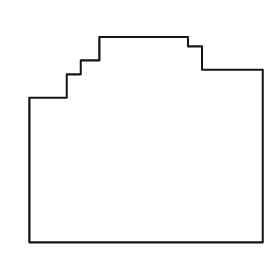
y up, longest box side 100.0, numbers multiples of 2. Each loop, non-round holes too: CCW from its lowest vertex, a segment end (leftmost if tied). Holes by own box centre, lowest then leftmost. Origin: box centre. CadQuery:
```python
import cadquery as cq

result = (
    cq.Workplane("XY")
    .moveTo(-50.0, -44.0)
    .lineTo(50.0, -44.0)
    .lineTo(50.0, 30.0)
    .lineTo(24.0, 30.0)
    .lineTo(24.0, 40.0)
    .lineTo(18.0, 40.0)
    .lineTo(18.0, 44.0)
    .lineTo(-20.0, 44.0)
    .lineTo(-20.0, 34.0)
    .lineTo(-28.0, 34.0)
    .lineTo(-28.0, 28.0)
    .lineTo(-34.0, 28.0)
    .lineTo(-34.0, 18.0)
    .lineTo(-50.0, 18.0)
    .close()
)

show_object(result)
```